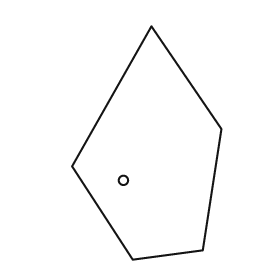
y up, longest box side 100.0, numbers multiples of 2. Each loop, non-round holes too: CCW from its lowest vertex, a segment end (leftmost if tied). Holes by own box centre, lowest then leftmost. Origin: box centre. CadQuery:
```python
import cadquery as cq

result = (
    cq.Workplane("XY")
    .moveTo(-6.0, -50.0)
    .lineTo(24.0, -46.0)
    .lineTo(32.0, 6.0)
    .lineTo(2.0, 50.0)
    .lineTo(-32.0, -10.0)
    .close()
    .moveTo(-10.0, -16.0)
    .circle(2.0)
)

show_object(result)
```